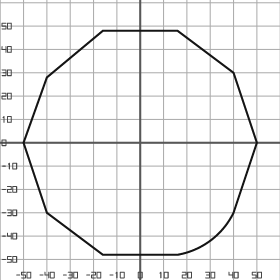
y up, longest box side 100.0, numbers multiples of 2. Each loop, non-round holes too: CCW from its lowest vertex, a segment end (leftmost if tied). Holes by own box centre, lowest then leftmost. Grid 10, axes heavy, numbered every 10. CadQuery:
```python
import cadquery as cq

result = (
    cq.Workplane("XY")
    .moveTo(-16.0, -48.0)
    .lineTo(16.0, -48.0)
    .threePointArc((30.0, -42.0), (40.0, -30.0))
    .lineTo(50.0, 0.0)
    .lineTo(40.0, 30.0)
    .lineTo(16.0, 48.0)
    .lineTo(-16.0, 48.0)
    .lineTo(-40.0, 28.0)
    .lineTo(-50.0, 0.0)
    .lineTo(-40.0, -30.0)
    .close()
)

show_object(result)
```